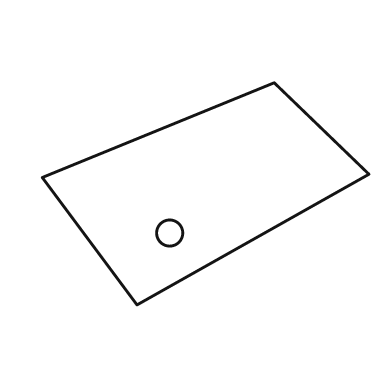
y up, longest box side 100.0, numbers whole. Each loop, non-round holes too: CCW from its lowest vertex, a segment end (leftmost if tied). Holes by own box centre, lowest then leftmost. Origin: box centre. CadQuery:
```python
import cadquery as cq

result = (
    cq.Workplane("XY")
    .moveTo(-21.0, -34.0)
    .lineTo(50.0, 6.0)
    .lineTo(21.0, 34.0)
    .lineTo(-50.0, 5.0)
    .close()
    .moveTo(-11.0, -12.0)
    .circle(4.0)
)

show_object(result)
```